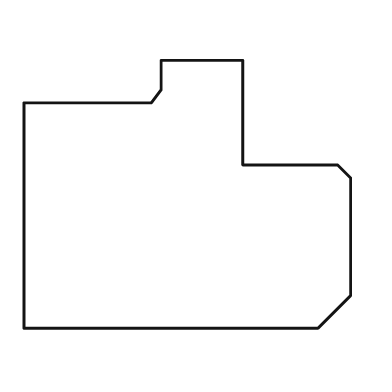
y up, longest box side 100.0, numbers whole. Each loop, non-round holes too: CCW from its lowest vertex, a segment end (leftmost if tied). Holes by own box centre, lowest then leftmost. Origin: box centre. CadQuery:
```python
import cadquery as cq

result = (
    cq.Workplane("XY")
    .moveTo(-50.0, -41.0)
    .lineTo(40.0, -41.0)
    .lineTo(50.0, -31.0)
    .lineTo(50.0, 5.0)
    .lineTo(46.0, 9.0)
    .lineTo(17.0, 9.0)
    .lineTo(17.0, 41.0)
    .lineTo(-8.0, 41.0)
    .lineTo(-8.0, 32.0)
    .lineTo(-11.0, 28.0)
    .lineTo(-50.0, 28.0)
    .close()
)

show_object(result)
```